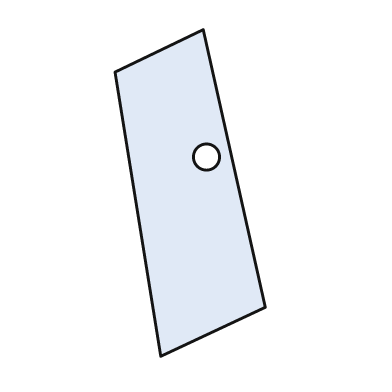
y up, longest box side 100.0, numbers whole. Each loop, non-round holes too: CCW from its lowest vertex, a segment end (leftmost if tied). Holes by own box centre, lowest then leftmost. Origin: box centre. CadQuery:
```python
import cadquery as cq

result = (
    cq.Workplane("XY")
    .moveTo(-9.0, -50.0)
    .lineTo(23.0, -35.0)
    .lineTo(4.0, 50.0)
    .lineTo(-23.0, 37.0)
    .close()
    .moveTo(5.0, 11.0)
    .circle(4.0)
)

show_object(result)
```